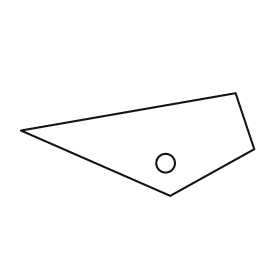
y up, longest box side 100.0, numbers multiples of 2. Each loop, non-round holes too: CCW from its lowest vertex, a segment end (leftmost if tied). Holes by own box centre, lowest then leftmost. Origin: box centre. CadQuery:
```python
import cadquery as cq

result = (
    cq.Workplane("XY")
    .moveTo(14.0, -22.0)
    .lineTo(50.0, -2.0)
    .lineTo(42.0, 22.0)
    .lineTo(-50.0, 6.0)
    .close()
    .moveTo(12.0, -8.0)
    .circle(4.0)
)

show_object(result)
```